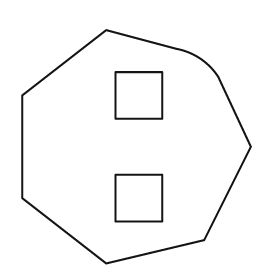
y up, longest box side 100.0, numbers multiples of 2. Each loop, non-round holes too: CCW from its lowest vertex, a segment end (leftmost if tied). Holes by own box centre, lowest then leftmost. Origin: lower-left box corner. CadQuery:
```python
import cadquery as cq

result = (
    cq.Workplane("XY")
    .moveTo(36.0, 0.0)
    .lineTo(78.0, 10.0)
    .lineTo(98.0, 50.0)
    .lineTo(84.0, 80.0)
    .threePointArc((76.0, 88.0), (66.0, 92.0))
    .lineTo(36.0, 100.0)
    .lineTo(0.0, 72.0)
    .lineTo(0.0, 28.0)
    .close()
    .moveTo(40.0, 18.0)
    .lineTo(60.0, 18.0)
    .lineTo(60.0, 38.0)
    .lineTo(40.0, 38.0)
    .close()
    .moveTo(40.0, 62.0)
    .lineTo(60.0, 62.0)
    .lineTo(60.0, 82.0)
    .lineTo(40.0, 82.0)
    .close()
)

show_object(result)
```